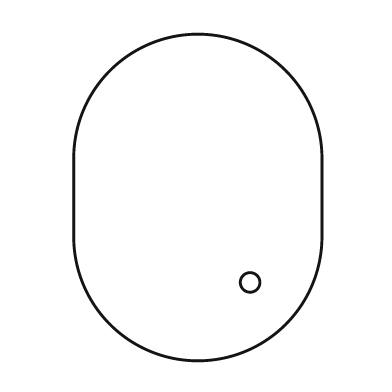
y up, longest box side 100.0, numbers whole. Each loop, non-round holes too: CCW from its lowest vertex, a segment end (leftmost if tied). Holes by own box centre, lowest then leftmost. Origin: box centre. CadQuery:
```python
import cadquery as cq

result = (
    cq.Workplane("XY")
    .moveTo(-38.0, -12.0)
    .threePointArc((0.0, -50.0), (38.0, -12.0))
    .lineTo(38.0, 12.0)
    .threePointArc((0.0, 50.0), (-38.0, 12.0))
    .close()
    .moveTo(16.0, -26.0)
    .circle(3.0)
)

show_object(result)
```